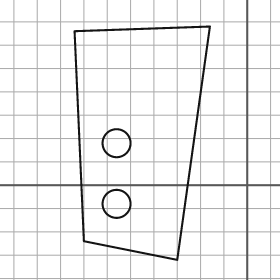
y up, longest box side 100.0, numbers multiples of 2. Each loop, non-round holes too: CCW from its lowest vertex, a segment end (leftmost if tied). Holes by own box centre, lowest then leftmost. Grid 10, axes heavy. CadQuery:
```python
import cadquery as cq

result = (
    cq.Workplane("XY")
    .moveTo(-30.0, -32.0)
    .lineTo(-16.0, 68.0)
    .lineTo(-74.0, 66.0)
    .lineTo(-70.0, -24.0)
    .close()
    .moveTo(-56.0, -8.0)
    .circle(6.0)
    .moveTo(-56.0, 18.0)
    .circle(6.0)
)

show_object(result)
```